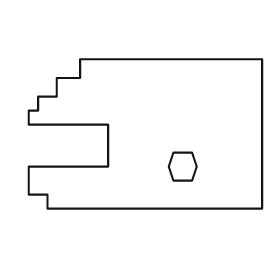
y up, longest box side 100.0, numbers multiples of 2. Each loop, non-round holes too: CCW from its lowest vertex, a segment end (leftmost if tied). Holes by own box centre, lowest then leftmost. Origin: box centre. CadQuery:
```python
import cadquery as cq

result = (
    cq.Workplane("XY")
    .moveTo(-42.0, -32.0)
    .lineTo(50.0, -32.0)
    .lineTo(50.0, 32.0)
    .lineTo(-28.0, 32.0)
    .lineTo(-28.0, 24.0)
    .lineTo(-38.0, 24.0)
    .lineTo(-38.0, 16.0)
    .lineTo(-46.0, 16.0)
    .lineTo(-46.0, 10.0)
    .lineTo(-50.0, 10.0)
    .lineTo(-50.0, 4.0)
    .lineTo(-16.0, 4.0)
    .lineTo(-16.0, -14.0)
    .lineTo(-50.0, -14.0)
    .lineTo(-50.0, -26.0)
    .lineTo(-42.0, -26.0)
    .close()
    .moveTo(12.0, -20.0)
    .lineTo(20.0, -20.0)
    .lineTo(22.0, -14.0)
    .lineTo(20.0, -8.0)
    .lineTo(12.0, -8.0)
    .lineTo(10.0, -14.0)
    .close()
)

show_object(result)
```